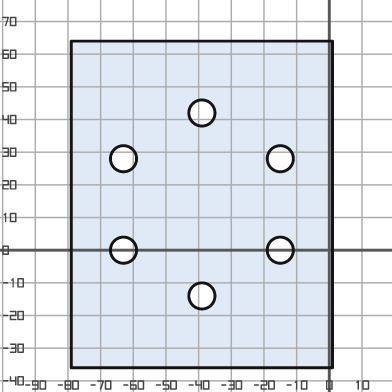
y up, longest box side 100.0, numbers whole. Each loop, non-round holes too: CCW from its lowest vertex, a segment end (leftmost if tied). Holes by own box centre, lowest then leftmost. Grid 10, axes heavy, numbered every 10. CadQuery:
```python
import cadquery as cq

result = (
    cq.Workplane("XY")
    .moveTo(-79.0, -36.0)
    .lineTo(1.0, -36.0)
    .lineTo(1.0, 64.0)
    .lineTo(-79.0, 64.0)
    .close()
    .moveTo(-39.0, -14.0)
    .circle(4.0)
    .moveTo(-63.0, 0.0)
    .circle(4.0)
    .moveTo(-15.0, 0.0)
    .circle(4.0)
    .moveTo(-63.0, 28.0)
    .circle(4.0)
    .moveTo(-15.0, 28.0)
    .circle(4.0)
    .moveTo(-39.0, 42.0)
    .circle(4.0)
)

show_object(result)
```